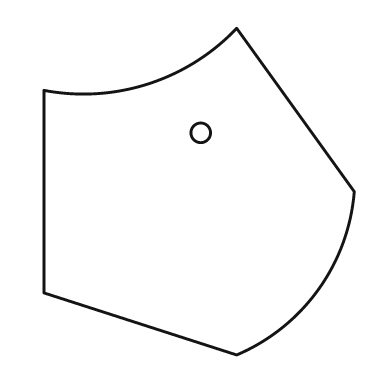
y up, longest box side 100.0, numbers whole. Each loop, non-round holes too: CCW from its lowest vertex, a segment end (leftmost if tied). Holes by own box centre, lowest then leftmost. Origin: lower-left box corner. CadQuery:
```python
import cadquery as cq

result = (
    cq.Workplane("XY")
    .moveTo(59.0, 0.0)
    .threePointArc((84.0, 20.0), (95.0, 50.0))
    .lineTo(59.0, 100.0)
    .threePointArc((32.0, 83.0), (0.0, 81.0))
    .lineTo(0.0, 19.0)
    .close()
    .moveTo(48.0, 68.0)
    .circle(3.0)
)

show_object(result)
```